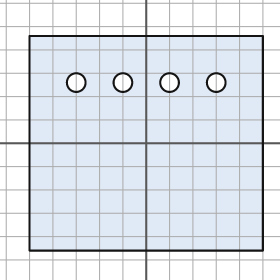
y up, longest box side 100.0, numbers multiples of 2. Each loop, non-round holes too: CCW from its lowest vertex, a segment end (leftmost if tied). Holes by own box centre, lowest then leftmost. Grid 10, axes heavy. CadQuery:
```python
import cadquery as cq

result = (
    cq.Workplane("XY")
    .moveTo(-50.0, -46.0)
    .lineTo(50.0, -46.0)
    .lineTo(50.0, 46.0)
    .lineTo(-50.0, 46.0)
    .close()
    .moveTo(-30.0, 26.0)
    .circle(4.0)
    .moveTo(-10.0, 26.0)
    .circle(4.0)
    .moveTo(10.0, 26.0)
    .circle(4.0)
    .moveTo(30.0, 26.0)
    .circle(4.0)
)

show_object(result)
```